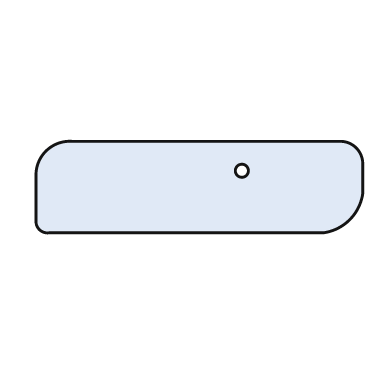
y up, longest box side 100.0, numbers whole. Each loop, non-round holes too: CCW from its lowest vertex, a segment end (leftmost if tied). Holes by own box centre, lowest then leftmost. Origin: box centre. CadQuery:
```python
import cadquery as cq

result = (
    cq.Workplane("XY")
    .moveTo(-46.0, -14.0)
    .lineTo(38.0, -14.0)
    .threePointArc((46.0, -10.0), (50.0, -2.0))
    .lineTo(50.0, 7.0)
    .threePointArc((48.0, 12.0), (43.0, 14.0))
    .lineTo(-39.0, 14.0)
    .threePointArc((-47.0, 11.0), (-50.0, 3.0))
    .lineTo(-50.0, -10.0)
    .threePointArc((-49.0, -13.0), (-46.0, -14.0))
    .close()
    .moveTo(13.0, 5.0)
    .circle(2.0)
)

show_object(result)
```